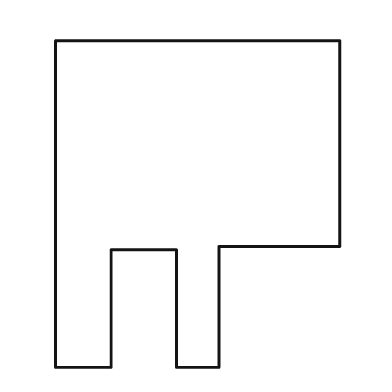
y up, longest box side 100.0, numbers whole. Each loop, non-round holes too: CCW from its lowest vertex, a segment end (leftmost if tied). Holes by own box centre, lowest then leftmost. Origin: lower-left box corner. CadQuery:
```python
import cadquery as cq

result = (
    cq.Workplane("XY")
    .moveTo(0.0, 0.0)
    .lineTo(17.0, 0.0)
    .lineTo(17.0, 36.0)
    .lineTo(37.0, 36.0)
    .lineTo(37.0, 0.0)
    .lineTo(50.0, 0.0)
    .lineTo(50.0, 37.0)
    .lineTo(87.0, 37.0)
    .lineTo(87.0, 100.0)
    .lineTo(0.0, 100.0)
    .close()
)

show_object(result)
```